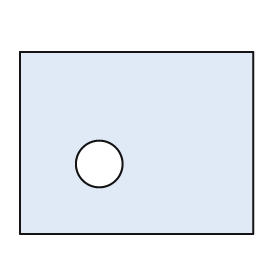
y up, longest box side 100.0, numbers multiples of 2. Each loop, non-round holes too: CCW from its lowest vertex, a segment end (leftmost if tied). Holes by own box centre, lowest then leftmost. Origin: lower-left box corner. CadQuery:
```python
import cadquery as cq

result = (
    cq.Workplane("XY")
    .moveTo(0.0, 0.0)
    .lineTo(100.0, 0.0)
    .lineTo(100.0, 78.0)
    .lineTo(0.0, 78.0)
    .close()
    .moveTo(34.0, 30.0)
    .circle(10.0)
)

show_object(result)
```